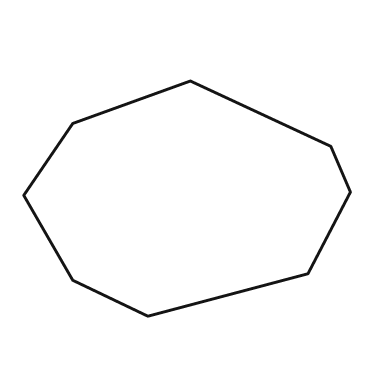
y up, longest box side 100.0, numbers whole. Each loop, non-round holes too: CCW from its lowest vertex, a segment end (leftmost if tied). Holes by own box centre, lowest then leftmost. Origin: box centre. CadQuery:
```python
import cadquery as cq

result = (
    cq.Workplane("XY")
    .moveTo(-12.0, -36.0)
    .lineTo(37.0, -23.0)
    .lineTo(50.0, 2.0)
    .lineTo(44.0, 16.0)
    .lineTo(1.0, 36.0)
    .lineTo(-35.0, 23.0)
    .lineTo(-50.0, 1.0)
    .lineTo(-35.0, -25.0)
    .close()
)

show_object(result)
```